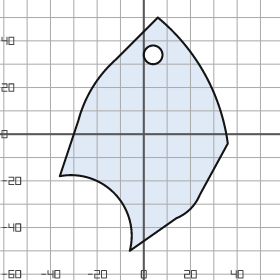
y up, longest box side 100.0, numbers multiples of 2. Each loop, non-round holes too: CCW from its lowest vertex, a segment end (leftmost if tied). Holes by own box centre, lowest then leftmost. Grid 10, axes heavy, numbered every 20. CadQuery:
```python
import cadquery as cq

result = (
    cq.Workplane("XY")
    .moveTo(-6.0, -50.0)
    .lineTo(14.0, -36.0)
    .threePointArc((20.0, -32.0), (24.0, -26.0))
    .lineTo(36.0, -4.0)
    .threePointArc((26.0, 26.0), (6.0, 50.0))
    .lineTo(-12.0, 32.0)
    .threePointArc((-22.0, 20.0), (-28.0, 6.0))
    .lineTo(-36.0, -18.0)
    .threePointArc((-12.0, -26.0), (-6.0, -50.0))
    .close()
    .moveTo(4.0, 34.0)
    .circle(4.0)
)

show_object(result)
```